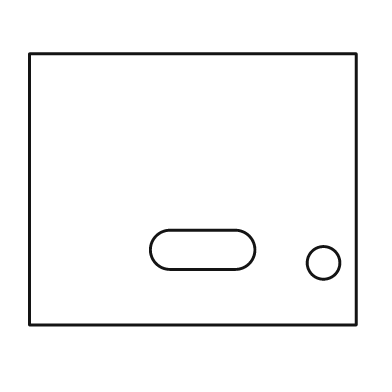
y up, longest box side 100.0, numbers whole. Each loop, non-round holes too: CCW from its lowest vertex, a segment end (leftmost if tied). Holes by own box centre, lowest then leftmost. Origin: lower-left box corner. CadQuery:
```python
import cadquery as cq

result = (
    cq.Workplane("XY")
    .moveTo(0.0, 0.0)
    .lineTo(100.0, 0.0)
    .lineTo(100.0, 83.0)
    .lineTo(0.0, 83.0)
    .close()
    .moveTo(90.0, 19.0)
    .circle(5.0)
    .moveTo(43.0, 17.0)
    .lineTo(63.0, 17.0)
    .threePointArc((69.0, 23.0), (63.0, 29.0))
    .lineTo(43.0, 29.0)
    .threePointArc((37.0, 23.0), (43.0, 17.0))
    .close()
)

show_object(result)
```